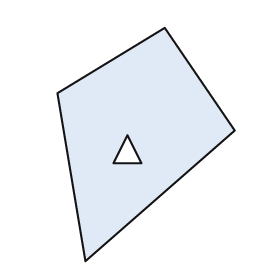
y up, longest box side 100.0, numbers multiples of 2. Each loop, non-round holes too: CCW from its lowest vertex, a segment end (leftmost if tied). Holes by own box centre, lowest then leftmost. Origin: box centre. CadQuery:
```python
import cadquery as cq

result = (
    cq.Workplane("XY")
    .moveTo(-26.0, -50.0)
    .lineTo(38.0, 6.0)
    .lineTo(8.0, 50.0)
    .lineTo(-38.0, 22.0)
    .close()
    .moveTo(-14.0, -8.0)
    .lineTo(-2.0, -8.0)
    .lineTo(-8.0, 4.0)
    .close()
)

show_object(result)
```